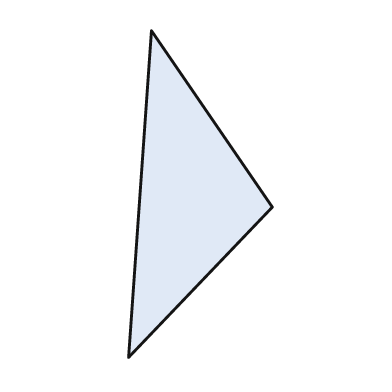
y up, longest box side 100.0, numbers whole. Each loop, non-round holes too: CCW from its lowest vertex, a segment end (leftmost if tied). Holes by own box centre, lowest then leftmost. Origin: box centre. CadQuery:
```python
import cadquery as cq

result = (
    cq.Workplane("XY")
    .moveTo(-22.0, -50.0)
    .lineTo(22.0, -4.0)
    .lineTo(-15.0, 50.0)
    .close()
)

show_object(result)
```